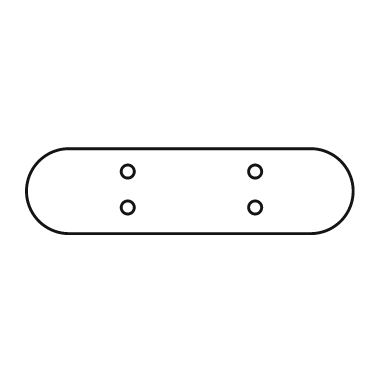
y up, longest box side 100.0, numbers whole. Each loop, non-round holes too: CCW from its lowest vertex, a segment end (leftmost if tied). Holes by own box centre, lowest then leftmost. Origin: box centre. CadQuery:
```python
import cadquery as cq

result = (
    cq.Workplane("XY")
    .moveTo(-37.0, -13.0)
    .lineTo(37.0, -13.0)
    .threePointArc((50.0, 0.0), (37.0, 13.0))
    .lineTo(-37.0, 13.0)
    .threePointArc((-50.0, 0.0), (-37.0, -13.0))
    .close()
    .moveTo(-19.0, -5.0)
    .circle(2.0)
    .moveTo(20.0, -5.0)
    .circle(2.0)
    .moveTo(-19.0, 6.0)
    .circle(2.0)
    .moveTo(20.0, 6.0)
    .circle(2.0)
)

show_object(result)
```